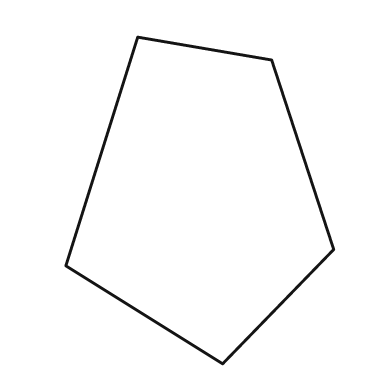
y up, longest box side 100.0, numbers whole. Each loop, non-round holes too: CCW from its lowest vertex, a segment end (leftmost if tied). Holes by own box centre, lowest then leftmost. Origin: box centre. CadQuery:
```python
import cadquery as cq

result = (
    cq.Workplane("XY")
    .moveTo(7.0, -50.0)
    .lineTo(41.0, -15.0)
    .lineTo(22.0, 43.0)
    .lineTo(-19.0, 50.0)
    .lineTo(-41.0, -20.0)
    .close()
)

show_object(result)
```